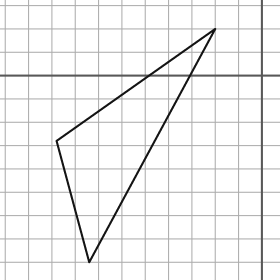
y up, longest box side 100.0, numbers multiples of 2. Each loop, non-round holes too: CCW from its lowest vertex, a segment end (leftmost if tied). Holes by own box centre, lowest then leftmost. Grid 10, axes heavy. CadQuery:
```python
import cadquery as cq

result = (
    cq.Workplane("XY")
    .moveTo(-74.0, -80.0)
    .lineTo(-20.0, 20.0)
    .lineTo(-88.0, -28.0)
    .close()
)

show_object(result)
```